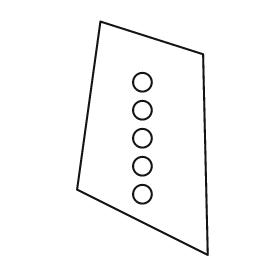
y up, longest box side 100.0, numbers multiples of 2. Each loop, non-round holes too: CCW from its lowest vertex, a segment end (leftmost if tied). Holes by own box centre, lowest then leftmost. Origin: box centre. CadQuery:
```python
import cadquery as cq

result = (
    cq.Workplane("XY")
    .moveTo(28.0, -50.0)
    .lineTo(26.0, 36.0)
    .lineTo(-18.0, 50.0)
    .lineTo(-28.0, -22.0)
    .close()
    .moveTo(0.0, -24.0)
    .circle(4.0)
    .moveTo(0.0, -12.0)
    .circle(4.0)
    .moveTo(0.0, 0.0)
    .circle(4.0)
    .moveTo(0.0, 12.0)
    .circle(4.0)
    .moveTo(0.0, 24.0)
    .circle(4.0)
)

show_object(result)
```